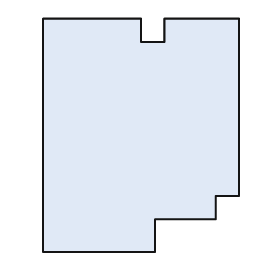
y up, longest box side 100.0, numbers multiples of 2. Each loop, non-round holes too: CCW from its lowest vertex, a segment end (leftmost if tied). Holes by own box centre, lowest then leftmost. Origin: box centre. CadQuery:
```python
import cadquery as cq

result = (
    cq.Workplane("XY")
    .moveTo(-42.0, -50.0)
    .lineTo(6.0, -50.0)
    .lineTo(6.0, -36.0)
    .lineTo(32.0, -36.0)
    .lineTo(32.0, -26.0)
    .lineTo(42.0, -26.0)
    .lineTo(42.0, 50.0)
    .lineTo(10.0, 50.0)
    .lineTo(10.0, 40.0)
    .lineTo(0.0, 40.0)
    .lineTo(0.0, 50.0)
    .lineTo(-42.0, 50.0)
    .close()
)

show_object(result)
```